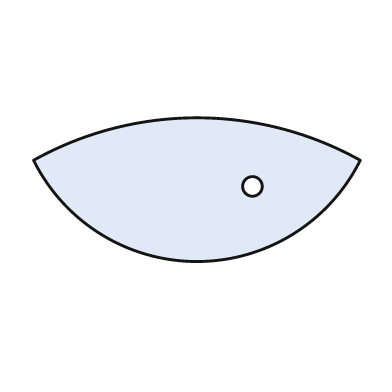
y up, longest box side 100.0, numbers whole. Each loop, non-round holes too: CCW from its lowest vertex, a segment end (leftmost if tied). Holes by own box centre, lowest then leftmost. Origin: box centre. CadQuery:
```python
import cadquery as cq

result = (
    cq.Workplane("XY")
    .moveTo(-50.0, 9.0)
    .threePointArc((0.0, -22.0), (50.0, 9.0))
    .threePointArc((0.0, 22.0), (-50.0, 9.0))
    .close()
    .moveTo(17.0, 1.0)
    .circle(3.0)
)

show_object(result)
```